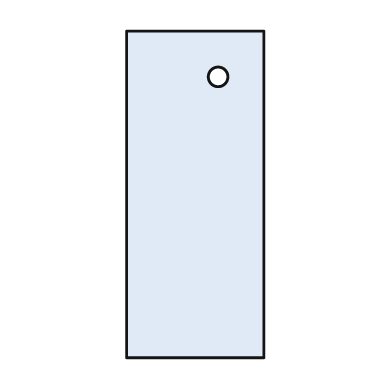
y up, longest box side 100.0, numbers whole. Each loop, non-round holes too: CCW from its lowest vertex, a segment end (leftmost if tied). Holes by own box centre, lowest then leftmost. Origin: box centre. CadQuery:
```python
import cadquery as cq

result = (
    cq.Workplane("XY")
    .moveTo(-21.0, -50.0)
    .lineTo(21.0, -50.0)
    .lineTo(21.0, 50.0)
    .lineTo(-21.0, 50.0)
    .close()
    .moveTo(7.0, 36.0)
    .circle(3.0)
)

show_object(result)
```